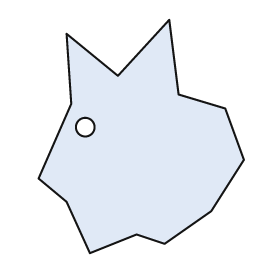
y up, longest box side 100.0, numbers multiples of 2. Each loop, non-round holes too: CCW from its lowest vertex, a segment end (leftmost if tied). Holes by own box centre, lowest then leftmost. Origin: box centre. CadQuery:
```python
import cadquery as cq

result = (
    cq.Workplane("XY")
    .moveTo(-22.0, -50.0)
    .lineTo(-2.0, -42.0)
    .lineTo(10.0, -46.0)
    .lineTo(30.0, -32.0)
    .lineTo(44.0, -10.0)
    .lineTo(36.0, 12.0)
    .lineTo(16.0, 18.0)
    .lineTo(12.0, 50.0)
    .lineTo(-10.0, 26.0)
    .lineTo(-32.0, 44.0)
    .lineTo(-30.0, 14.0)
    .lineTo(-44.0, -18.0)
    .lineTo(-32.0, -28.0)
    .close()
    .moveTo(-24.0, 4.0)
    .circle(4.0)
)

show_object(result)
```